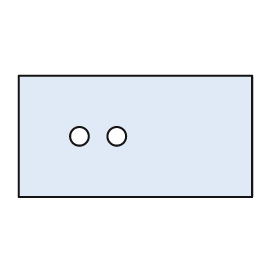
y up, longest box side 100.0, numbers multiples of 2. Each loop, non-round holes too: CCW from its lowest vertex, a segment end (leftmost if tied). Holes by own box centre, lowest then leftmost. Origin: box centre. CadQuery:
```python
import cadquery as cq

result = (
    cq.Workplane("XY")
    .moveTo(-50.0, -26.0)
    .lineTo(50.0, -26.0)
    .lineTo(50.0, 26.0)
    .lineTo(-50.0, 26.0)
    .close()
    .moveTo(-24.0, 0.0)
    .circle(4.0)
    .moveTo(-8.0, 0.0)
    .circle(4.0)
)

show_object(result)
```